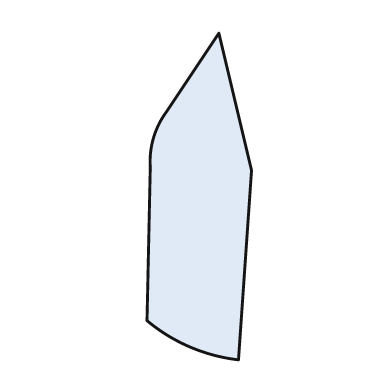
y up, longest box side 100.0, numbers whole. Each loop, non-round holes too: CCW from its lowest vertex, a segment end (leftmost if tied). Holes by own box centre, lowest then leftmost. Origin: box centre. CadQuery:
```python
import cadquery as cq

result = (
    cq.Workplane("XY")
    .moveTo(12.0, -50.0)
    .lineTo(16.0, 8.0)
    .lineTo(6.0, 50.0)
    .lineTo(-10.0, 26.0)
    .threePointArc((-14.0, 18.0), (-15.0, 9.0))
    .lineTo(-16.0, -38.0)
    .threePointArc((-3.0, -46.0), (12.0, -50.0))
    .close()
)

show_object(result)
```